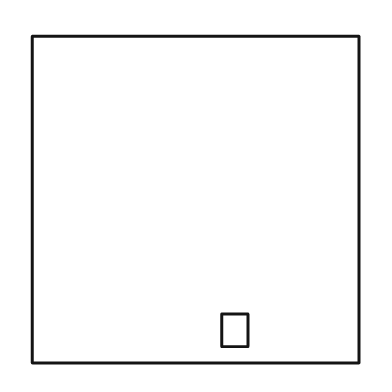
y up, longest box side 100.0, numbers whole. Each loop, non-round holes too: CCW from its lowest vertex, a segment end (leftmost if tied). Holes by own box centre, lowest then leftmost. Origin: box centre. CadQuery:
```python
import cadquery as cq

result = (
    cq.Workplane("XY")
    .moveTo(-50.0, -50.0)
    .lineTo(50.0, -50.0)
    .lineTo(50.0, 50.0)
    .lineTo(-50.0, 50.0)
    .close()
    .moveTo(8.0, -45.0)
    .lineTo(16.0, -45.0)
    .lineTo(16.0, -35.0)
    .lineTo(8.0, -35.0)
    .close()
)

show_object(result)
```